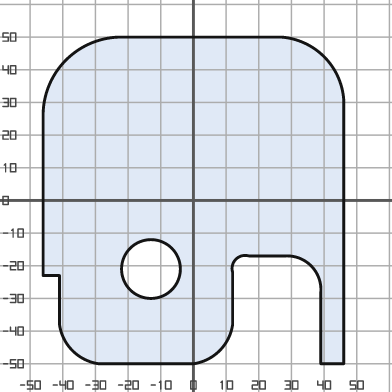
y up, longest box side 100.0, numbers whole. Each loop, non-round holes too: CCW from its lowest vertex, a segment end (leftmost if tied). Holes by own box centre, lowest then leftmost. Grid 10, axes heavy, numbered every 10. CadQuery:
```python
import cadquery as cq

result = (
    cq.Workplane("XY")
    .moveTo(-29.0, -50.0)
    .lineTo(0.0, -50.0)
    .threePointArc((8.0, -46.0), (12.0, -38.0))
    .lineTo(12.0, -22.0)
    .threePointArc((13.0, -18.0), (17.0, -17.0))
    .lineTo(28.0, -17.0)
    .threePointArc((36.0, -20.0), (39.0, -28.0))
    .lineTo(39.0, -50.0)
    .lineTo(46.0, -50.0)
    .lineTo(46.0, 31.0)
    .threePointArc((40.0, 44.0), (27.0, 50.0))
    .lineTo(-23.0, 50.0)
    .threePointArc((-39.0, 43.0), (-46.0, 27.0))
    .lineTo(-46.0, -23.0)
    .lineTo(-41.0, -23.0)
    .lineTo(-41.0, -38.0)
    .threePointArc((-37.0, -46.0), (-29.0, -50.0))
    .close()
    .moveTo(-13.0, -21.0)
    .circle(9.0)
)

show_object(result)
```